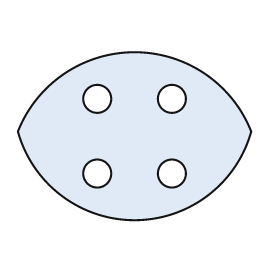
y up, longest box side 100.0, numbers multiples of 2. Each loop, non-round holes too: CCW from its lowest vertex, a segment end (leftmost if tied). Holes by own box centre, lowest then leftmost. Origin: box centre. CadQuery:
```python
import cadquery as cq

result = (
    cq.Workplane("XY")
    .moveTo(-50.0, 2.0)
    .threePointArc((0.0, -36.0), (50.0, 2.0))
    .threePointArc((0.0, 36.0), (-50.0, 2.0))
    .close()
    .moveTo(-16.0, -16.0)
    .circle(6.0)
    .moveTo(16.0, -16.0)
    .circle(6.0)
    .moveTo(-16.0, 16.0)
    .circle(6.0)
    .moveTo(16.0, 16.0)
    .circle(6.0)
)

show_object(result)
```